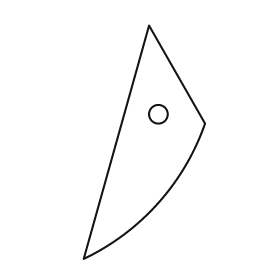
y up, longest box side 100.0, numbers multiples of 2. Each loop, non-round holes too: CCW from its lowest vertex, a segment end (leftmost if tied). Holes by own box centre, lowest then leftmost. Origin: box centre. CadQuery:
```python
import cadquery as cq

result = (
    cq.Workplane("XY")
    .moveTo(-26.0, -50.0)
    .threePointArc((6.0, -26.0), (26.0, 8.0))
    .lineTo(2.0, 50.0)
    .close()
    .moveTo(6.0, 12.0)
    .circle(4.0)
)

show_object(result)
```